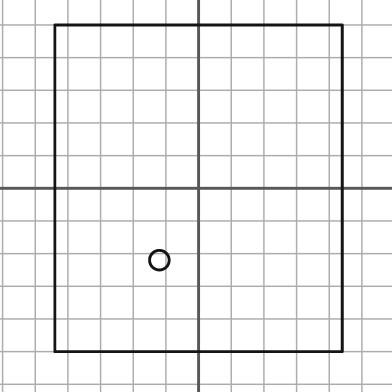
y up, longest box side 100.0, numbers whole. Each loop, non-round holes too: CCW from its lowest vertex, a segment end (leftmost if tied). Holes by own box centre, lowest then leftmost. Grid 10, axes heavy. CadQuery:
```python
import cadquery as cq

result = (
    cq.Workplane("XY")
    .moveTo(-44.0, -50.0)
    .lineTo(44.0, -50.0)
    .lineTo(44.0, 50.0)
    .lineTo(-44.0, 50.0)
    .close()
    .moveTo(-12.0, -22.0)
    .circle(3.0)
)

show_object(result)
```